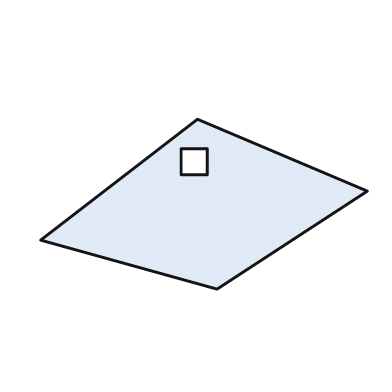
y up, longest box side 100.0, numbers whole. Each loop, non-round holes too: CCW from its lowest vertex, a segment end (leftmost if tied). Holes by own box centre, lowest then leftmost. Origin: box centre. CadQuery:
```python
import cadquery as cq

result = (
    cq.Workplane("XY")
    .moveTo(4.0, -26.0)
    .lineTo(50.0, 4.0)
    .lineTo(-2.0, 26.0)
    .lineTo(-50.0, -11.0)
    .close()
    .moveTo(-7.0, 9.0)
    .lineTo(1.0, 9.0)
    .lineTo(1.0, 17.0)
    .lineTo(-7.0, 17.0)
    .close()
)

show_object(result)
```